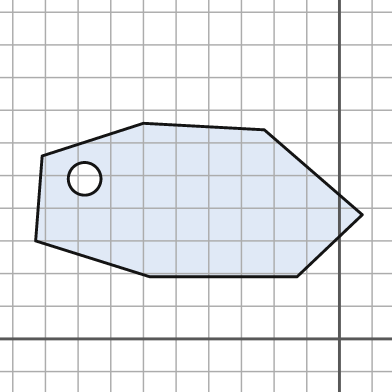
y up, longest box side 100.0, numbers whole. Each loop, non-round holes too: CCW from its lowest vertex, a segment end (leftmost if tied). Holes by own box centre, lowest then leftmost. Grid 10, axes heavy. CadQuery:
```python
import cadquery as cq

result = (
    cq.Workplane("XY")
    .moveTo(-58.0, 19.0)
    .lineTo(-13.0, 19.0)
    .lineTo(7.0, 38.0)
    .lineTo(-23.0, 64.0)
    .lineTo(-60.0, 66.0)
    .lineTo(-91.0, 56.0)
    .lineTo(-93.0, 30.0)
    .close()
    .moveTo(-78.0, 49.0)
    .circle(5.0)
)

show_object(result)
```